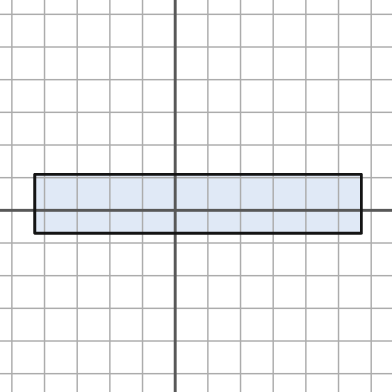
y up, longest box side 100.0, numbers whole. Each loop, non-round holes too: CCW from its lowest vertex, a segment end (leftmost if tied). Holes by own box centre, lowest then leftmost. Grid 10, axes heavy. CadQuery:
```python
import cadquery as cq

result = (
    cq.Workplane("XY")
    .moveTo(-43.0, -7.0)
    .lineTo(57.0, -7.0)
    .lineTo(57.0, 11.0)
    .lineTo(-43.0, 11.0)
    .close()
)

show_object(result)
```